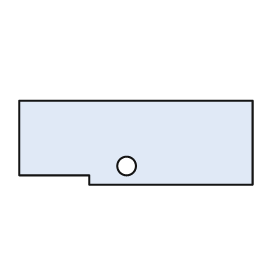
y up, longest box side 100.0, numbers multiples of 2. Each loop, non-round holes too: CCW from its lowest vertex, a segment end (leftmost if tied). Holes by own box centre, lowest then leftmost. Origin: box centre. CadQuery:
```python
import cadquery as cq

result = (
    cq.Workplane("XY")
    .moveTo(-20.0, -18.0)
    .lineTo(50.0, -18.0)
    .lineTo(50.0, 18.0)
    .lineTo(-50.0, 18.0)
    .lineTo(-50.0, -14.0)
    .lineTo(-20.0, -14.0)
    .close()
    .moveTo(-4.0, -10.0)
    .circle(4.0)
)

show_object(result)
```